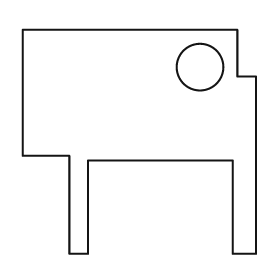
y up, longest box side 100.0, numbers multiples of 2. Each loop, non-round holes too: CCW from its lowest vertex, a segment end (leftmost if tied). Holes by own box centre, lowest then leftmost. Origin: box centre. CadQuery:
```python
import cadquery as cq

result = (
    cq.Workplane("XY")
    .moveTo(-30.0, -48.0)
    .lineTo(-22.0, -48.0)
    .lineTo(-22.0, -8.0)
    .lineTo(40.0, -8.0)
    .lineTo(40.0, -48.0)
    .lineTo(50.0, -48.0)
    .lineTo(50.0, 28.0)
    .lineTo(42.0, 28.0)
    .lineTo(42.0, 48.0)
    .lineTo(-50.0, 48.0)
    .lineTo(-50.0, -6.0)
    .lineTo(-30.0, -6.0)
    .close()
    .moveTo(26.0, 32.0)
    .circle(10.0)
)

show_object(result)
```